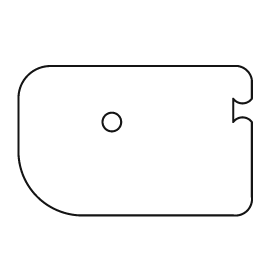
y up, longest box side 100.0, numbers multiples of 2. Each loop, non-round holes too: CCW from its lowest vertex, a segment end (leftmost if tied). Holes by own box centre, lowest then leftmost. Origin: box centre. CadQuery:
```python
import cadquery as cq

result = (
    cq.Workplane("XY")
    .moveTo(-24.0, -32.0)
    .lineTo(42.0, -32.0)
    .threePointArc((48.0, -30.0), (50.0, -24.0))
    .lineTo(50.0, 8.0)
    .threePointArc((46.0, 10.0), (42.0, 8.0))
    .lineTo(42.0, 18.0)
    .threePointArc((46.0, 16.0), (50.0, 18.0))
    .lineTo(50.0, 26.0)
    .threePointArc((48.0, 30.0), (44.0, 32.0))
    .lineTo(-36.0, 32.0)
    .threePointArc((-46.0, 28.0), (-50.0, 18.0))
    .lineTo(-50.0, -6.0)
    .threePointArc((-42.0, -24.0), (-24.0, -32.0))
    .close()
    .moveTo(-10.0, 8.0)
    .circle(4.0)
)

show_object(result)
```